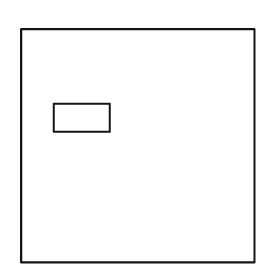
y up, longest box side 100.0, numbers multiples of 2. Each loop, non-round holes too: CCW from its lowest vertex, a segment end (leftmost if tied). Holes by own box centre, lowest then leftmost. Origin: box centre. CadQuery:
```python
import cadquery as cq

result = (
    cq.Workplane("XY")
    .moveTo(-50.0, -50.0)
    .lineTo(50.0, -50.0)
    .lineTo(50.0, 50.0)
    .lineTo(-50.0, 50.0)
    .close()
    .moveTo(-36.0, 6.0)
    .lineTo(-12.0, 6.0)
    .lineTo(-12.0, 18.0)
    .lineTo(-36.0, 18.0)
    .close()
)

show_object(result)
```